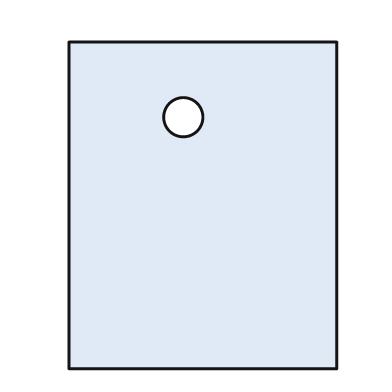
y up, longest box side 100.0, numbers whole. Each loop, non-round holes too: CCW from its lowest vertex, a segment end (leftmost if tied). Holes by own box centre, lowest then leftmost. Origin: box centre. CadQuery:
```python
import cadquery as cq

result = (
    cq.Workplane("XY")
    .moveTo(-41.0, -50.0)
    .lineTo(41.0, -50.0)
    .lineTo(41.0, 50.0)
    .lineTo(-41.0, 50.0)
    .close()
    .moveTo(-6.0, 27.0)
    .circle(6.0)
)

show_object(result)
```